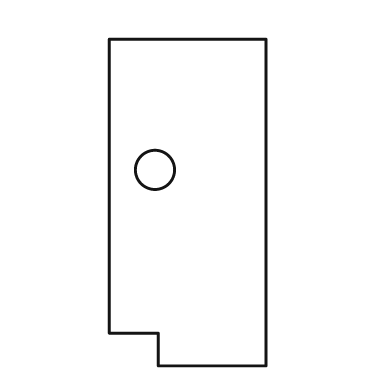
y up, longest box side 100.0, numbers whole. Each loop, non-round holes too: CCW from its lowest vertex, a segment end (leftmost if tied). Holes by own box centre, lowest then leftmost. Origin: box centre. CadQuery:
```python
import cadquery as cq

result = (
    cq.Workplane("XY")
    .moveTo(-9.0, -50.0)
    .lineTo(24.0, -50.0)
    .lineTo(24.0, 50.0)
    .lineTo(-24.0, 50.0)
    .lineTo(-24.0, -40.0)
    .lineTo(-9.0, -40.0)
    .close()
    .moveTo(-10.0, 10.0)
    .circle(6.0)
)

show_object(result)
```